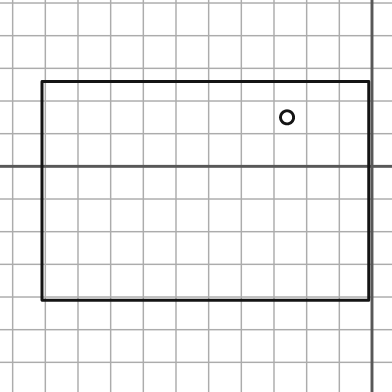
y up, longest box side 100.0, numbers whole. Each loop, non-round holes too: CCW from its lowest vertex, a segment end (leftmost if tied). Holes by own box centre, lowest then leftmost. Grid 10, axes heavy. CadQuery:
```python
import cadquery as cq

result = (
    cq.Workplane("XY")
    .moveTo(-101.0, -41.0)
    .lineTo(-1.0, -41.0)
    .lineTo(-1.0, 26.0)
    .lineTo(-101.0, 26.0)
    .close()
    .moveTo(-26.0, 15.0)
    .circle(2.0)
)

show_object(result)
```